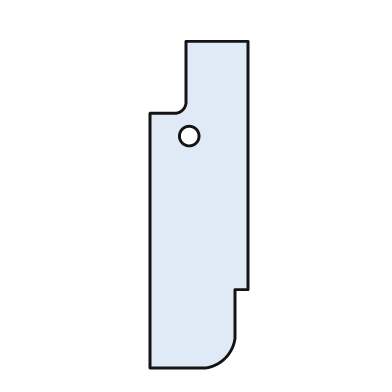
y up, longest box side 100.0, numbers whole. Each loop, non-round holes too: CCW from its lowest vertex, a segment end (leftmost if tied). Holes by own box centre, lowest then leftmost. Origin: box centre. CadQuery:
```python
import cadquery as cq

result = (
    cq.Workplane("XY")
    .moveTo(-15.0, -50.0)
    .lineTo(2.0, -50.0)
    .threePointArc((8.0, -47.0), (11.0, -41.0))
    .lineTo(11.0, -26.0)
    .lineTo(15.0, -26.0)
    .lineTo(15.0, 50.0)
    .lineTo(-4.0, 50.0)
    .lineTo(-4.0, 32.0)
    .threePointArc((-5.0, 29.0), (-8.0, 28.0))
    .lineTo(-15.0, 28.0)
    .close()
    .moveTo(-3.0, 21.0)
    .circle(3.0)
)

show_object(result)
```